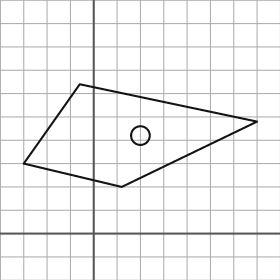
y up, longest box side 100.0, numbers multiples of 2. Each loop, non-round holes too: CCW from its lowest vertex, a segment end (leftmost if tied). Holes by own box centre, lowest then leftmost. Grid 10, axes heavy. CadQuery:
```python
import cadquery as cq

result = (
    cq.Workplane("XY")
    .moveTo(12.0, 20.0)
    .lineTo(70.0, 48.0)
    .lineTo(-6.0, 64.0)
    .lineTo(-30.0, 30.0)
    .close()
    .moveTo(20.0, 42.0)
    .circle(4.0)
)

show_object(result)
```